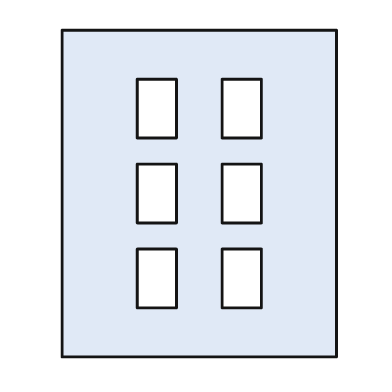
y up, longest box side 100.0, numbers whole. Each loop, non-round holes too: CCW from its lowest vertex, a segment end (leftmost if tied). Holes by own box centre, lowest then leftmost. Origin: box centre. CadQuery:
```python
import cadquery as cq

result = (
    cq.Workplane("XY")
    .moveTo(-42.0, -50.0)
    .lineTo(42.0, -50.0)
    .lineTo(42.0, 50.0)
    .lineTo(-42.0, 50.0)
    .close()
    .moveTo(-19.0, -35.0)
    .lineTo(-7.0, -35.0)
    .lineTo(-7.0, -17.0)
    .lineTo(-19.0, -17.0)
    .close()
    .moveTo(7.0, -35.0)
    .lineTo(19.0, -35.0)
    .lineTo(19.0, -17.0)
    .lineTo(7.0, -17.0)
    .close()
    .moveTo(-19.0, -9.0)
    .lineTo(-7.0, -9.0)
    .lineTo(-7.0, 9.0)
    .lineTo(-19.0, 9.0)
    .close()
    .moveTo(7.0, -9.0)
    .lineTo(19.0, -9.0)
    .lineTo(19.0, 9.0)
    .lineTo(7.0, 9.0)
    .close()
    .moveTo(-19.0, 17.0)
    .lineTo(-7.0, 17.0)
    .lineTo(-7.0, 35.0)
    .lineTo(-19.0, 35.0)
    .close()
    .moveTo(7.0, 17.0)
    .lineTo(19.0, 17.0)
    .lineTo(19.0, 35.0)
    .lineTo(7.0, 35.0)
    .close()
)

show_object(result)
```